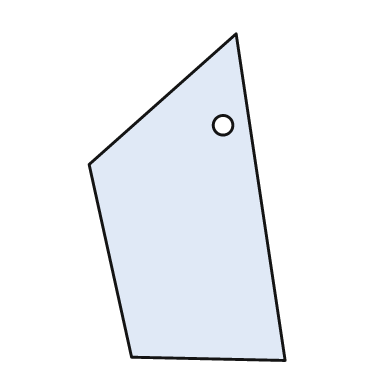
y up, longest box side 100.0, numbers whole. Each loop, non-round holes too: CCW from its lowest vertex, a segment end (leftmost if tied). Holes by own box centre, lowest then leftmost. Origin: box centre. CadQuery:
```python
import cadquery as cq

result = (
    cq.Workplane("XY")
    .moveTo(30.0, -50.0)
    .lineTo(15.0, 50.0)
    .lineTo(-30.0, 10.0)
    .lineTo(-17.0, -49.0)
    .close()
    .moveTo(11.0, 22.0)
    .circle(3.0)
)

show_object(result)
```